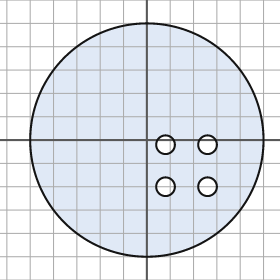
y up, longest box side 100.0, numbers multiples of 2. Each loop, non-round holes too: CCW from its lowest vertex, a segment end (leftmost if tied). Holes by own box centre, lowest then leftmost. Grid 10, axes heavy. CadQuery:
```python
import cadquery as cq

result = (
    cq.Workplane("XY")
    .moveTo(0.0, 0.0)
    .circle(50.0)
    .moveTo(8.0, -20.0)
    .circle(4.0)
    .moveTo(26.0, -20.0)
    .circle(4.0)
    .moveTo(8.0, -2.0)
    .circle(4.0)
    .moveTo(26.0, -2.0)
    .circle(4.0)
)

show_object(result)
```